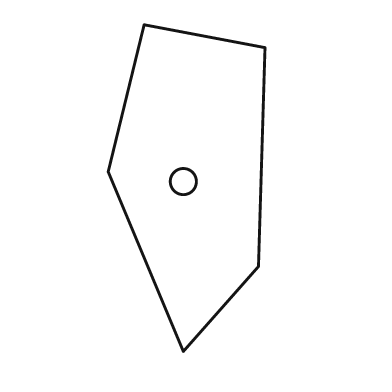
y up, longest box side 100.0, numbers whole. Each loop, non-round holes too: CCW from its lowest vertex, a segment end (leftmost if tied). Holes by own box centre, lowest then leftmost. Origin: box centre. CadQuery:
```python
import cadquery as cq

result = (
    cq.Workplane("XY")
    .moveTo(-1.0, -50.0)
    .lineTo(22.0, -24.0)
    .lineTo(24.0, 43.0)
    .lineTo(-13.0, 50.0)
    .lineTo(-24.0, 5.0)
    .close()
    .moveTo(-1.0, 2.0)
    .circle(4.0)
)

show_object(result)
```